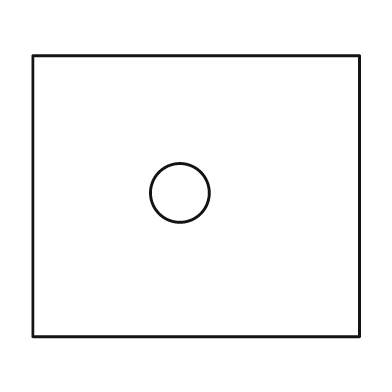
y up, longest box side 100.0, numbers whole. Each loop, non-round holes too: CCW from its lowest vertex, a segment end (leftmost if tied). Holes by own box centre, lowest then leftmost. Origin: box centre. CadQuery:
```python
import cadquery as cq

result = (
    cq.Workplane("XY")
    .moveTo(-50.0, -43.0)
    .lineTo(50.0, -43.0)
    .lineTo(50.0, 43.0)
    .lineTo(-50.0, 43.0)
    .close()
    .moveTo(-5.0, 1.0)
    .circle(9.0)
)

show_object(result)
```